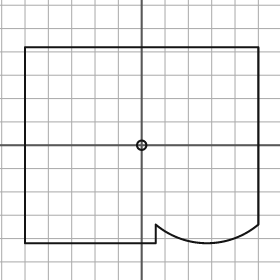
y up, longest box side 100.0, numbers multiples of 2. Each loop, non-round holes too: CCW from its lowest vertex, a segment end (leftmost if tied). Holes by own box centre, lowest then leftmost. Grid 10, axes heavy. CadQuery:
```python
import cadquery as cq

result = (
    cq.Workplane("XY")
    .moveTo(-50.0, -42.0)
    .lineTo(6.0, -42.0)
    .lineTo(6.0, -34.0)
    .threePointArc((28.0, -42.0), (50.0, -34.0))
    .lineTo(50.0, 42.0)
    .lineTo(-50.0, 42.0)
    .close()
    .moveTo(0.0, 0.0)
    .circle(2.0)
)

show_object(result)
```